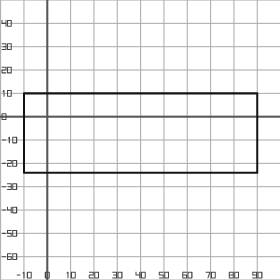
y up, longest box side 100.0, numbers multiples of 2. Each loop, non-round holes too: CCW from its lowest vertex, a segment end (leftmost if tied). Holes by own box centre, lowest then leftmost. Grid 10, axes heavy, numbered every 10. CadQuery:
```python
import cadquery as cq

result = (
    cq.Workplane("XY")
    .moveTo(-10.0, -24.0)
    .lineTo(90.0, -24.0)
    .lineTo(90.0, 10.0)
    .lineTo(-10.0, 10.0)
    .close()
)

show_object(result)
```